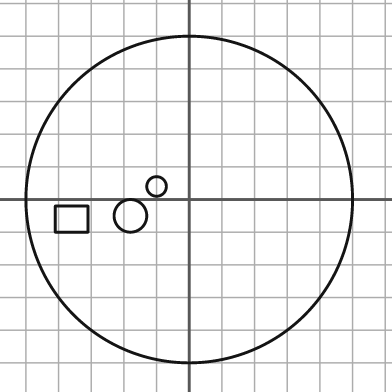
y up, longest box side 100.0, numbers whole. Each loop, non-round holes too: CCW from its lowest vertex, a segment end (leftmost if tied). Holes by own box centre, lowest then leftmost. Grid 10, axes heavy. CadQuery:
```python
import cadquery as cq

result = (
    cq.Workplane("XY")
    .moveTo(0.0, 0.0)
    .circle(50.0)
    .moveTo(-41.0, -10.0)
    .lineTo(-31.0, -10.0)
    .lineTo(-31.0, -2.0)
    .lineTo(-41.0, -2.0)
    .close()
    .moveTo(-18.0, -5.0)
    .circle(5.0)
    .moveTo(-10.0, 4.0)
    .circle(3.0)
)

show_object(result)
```